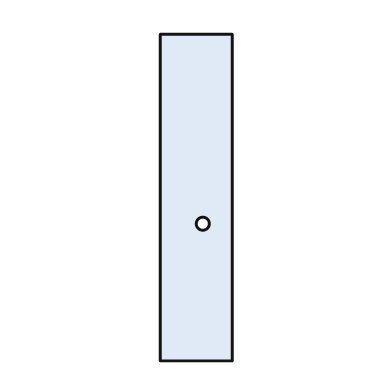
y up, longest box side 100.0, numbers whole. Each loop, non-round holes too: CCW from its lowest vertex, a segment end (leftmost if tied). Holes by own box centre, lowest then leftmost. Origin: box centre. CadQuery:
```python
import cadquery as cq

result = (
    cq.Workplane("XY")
    .moveTo(-11.0, -50.0)
    .lineTo(11.0, -50.0)
    .lineTo(11.0, 50.0)
    .lineTo(-11.0, 50.0)
    .close()
    .moveTo(2.0, -8.0)
    .circle(2.0)
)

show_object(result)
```